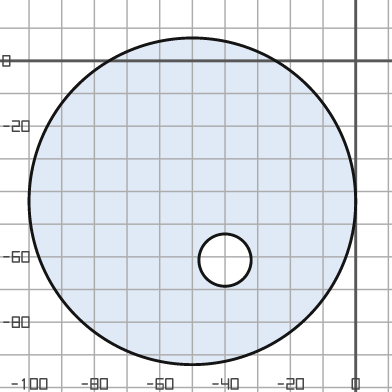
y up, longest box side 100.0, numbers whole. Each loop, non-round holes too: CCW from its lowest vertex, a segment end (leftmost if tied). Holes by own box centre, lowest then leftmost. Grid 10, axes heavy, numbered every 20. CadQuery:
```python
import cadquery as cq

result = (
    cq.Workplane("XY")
    .moveTo(-50.0, -43.0)
    .circle(50.0)
    .moveTo(-40.0, -61.0)
    .circle(8.0)
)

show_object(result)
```